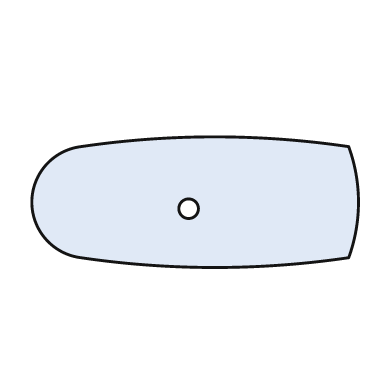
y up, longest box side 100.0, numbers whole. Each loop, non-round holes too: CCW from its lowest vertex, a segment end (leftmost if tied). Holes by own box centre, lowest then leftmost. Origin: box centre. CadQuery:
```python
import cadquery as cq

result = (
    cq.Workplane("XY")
    .moveTo(-35.0, -17.0)
    .threePointArc((6.0, -20.0), (47.0, -17.0))
    .threePointArc((50.0, 0.0), (47.0, 17.0))
    .threePointArc((6.0, 20.0), (-35.0, 17.0))
    .threePointArc((-50.0, 0.0), (-35.0, -17.0))
    .close()
    .moveTo(-2.0, -2.0)
    .circle(3.0)
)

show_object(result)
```